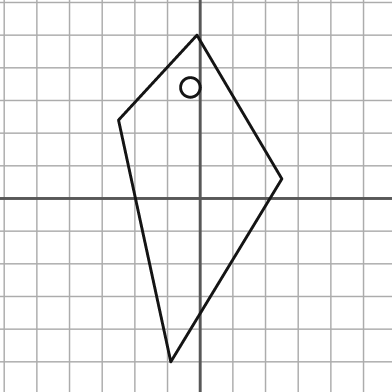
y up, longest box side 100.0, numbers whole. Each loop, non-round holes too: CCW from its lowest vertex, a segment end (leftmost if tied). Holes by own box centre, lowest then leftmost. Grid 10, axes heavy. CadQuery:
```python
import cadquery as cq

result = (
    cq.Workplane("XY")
    .moveTo(-9.0, -50.0)
    .lineTo(25.0, 6.0)
    .lineTo(-1.0, 50.0)
    .lineTo(-25.0, 24.0)
    .close()
    .moveTo(-3.0, 34.0)
    .circle(3.0)
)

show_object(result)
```